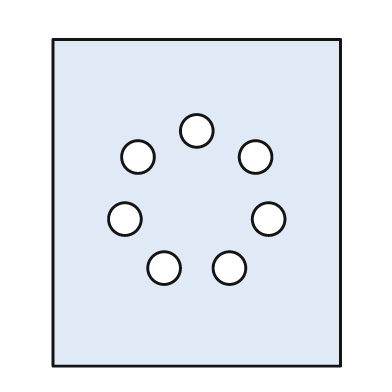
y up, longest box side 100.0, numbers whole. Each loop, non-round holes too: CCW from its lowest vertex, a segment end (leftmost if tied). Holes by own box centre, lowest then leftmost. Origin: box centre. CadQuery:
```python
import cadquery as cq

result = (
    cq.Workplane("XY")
    .moveTo(-44.0, -50.0)
    .lineTo(44.0, -50.0)
    .lineTo(44.0, 50.0)
    .lineTo(-44.0, 50.0)
    .close()
    .moveTo(-10.0, -20.0)
    .circle(5.0)
    .moveTo(10.0, -20.0)
    .circle(5.0)
    .moveTo(-22.0, -5.0)
    .circle(5.0)
    .moveTo(22.0, -5.0)
    .circle(5.0)
    .moveTo(-18.0, 14.0)
    .circle(5.0)
    .moveTo(18.0, 14.0)
    .circle(5.0)
    .moveTo(0.0, 22.0)
    .circle(5.0)
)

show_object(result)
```